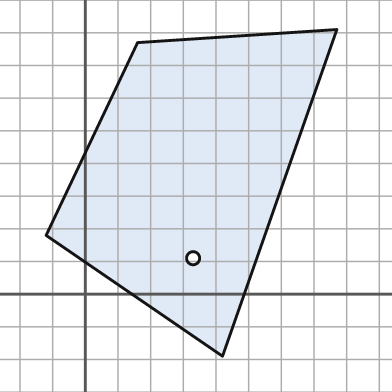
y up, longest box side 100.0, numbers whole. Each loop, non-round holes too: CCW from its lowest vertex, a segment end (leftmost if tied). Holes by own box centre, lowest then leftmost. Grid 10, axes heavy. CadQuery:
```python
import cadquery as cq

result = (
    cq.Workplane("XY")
    .moveTo(42.0, -19.0)
    .lineTo(77.0, 81.0)
    .lineTo(16.0, 77.0)
    .lineTo(-12.0, 18.0)
    .close()
    .moveTo(33.0, 11.0)
    .circle(2.0)
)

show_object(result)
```